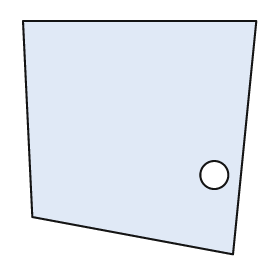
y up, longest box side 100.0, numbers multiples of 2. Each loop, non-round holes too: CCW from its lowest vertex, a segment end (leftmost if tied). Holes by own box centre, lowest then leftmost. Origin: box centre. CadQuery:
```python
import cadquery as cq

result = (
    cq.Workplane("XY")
    .moveTo(40.0, -50.0)
    .lineTo(50.0, 50.0)
    .lineTo(-50.0, 50.0)
    .lineTo(-46.0, -34.0)
    .close()
    .moveTo(32.0, -16.0)
    .circle(6.0)
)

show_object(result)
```